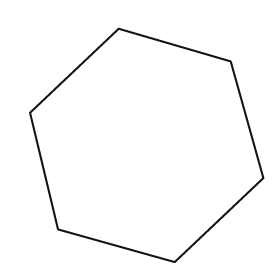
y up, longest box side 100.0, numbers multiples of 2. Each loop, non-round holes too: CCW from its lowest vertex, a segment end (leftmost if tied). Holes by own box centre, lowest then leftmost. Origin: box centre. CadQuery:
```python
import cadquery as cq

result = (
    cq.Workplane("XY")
    .moveTo(12.0, -50.0)
    .lineTo(50.0, -14.0)
    .lineTo(36.0, 36.0)
    .lineTo(-12.0, 50.0)
    .lineTo(-50.0, 14.0)
    .lineTo(-38.0, -36.0)
    .close()
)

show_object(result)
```